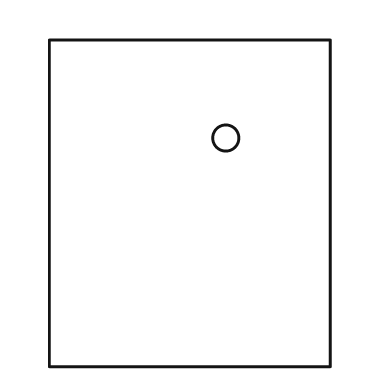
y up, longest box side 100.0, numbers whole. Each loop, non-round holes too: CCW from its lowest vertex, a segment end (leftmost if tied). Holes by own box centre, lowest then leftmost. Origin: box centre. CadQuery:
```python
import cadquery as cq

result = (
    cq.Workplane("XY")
    .moveTo(-43.0, -50.0)
    .lineTo(43.0, -50.0)
    .lineTo(43.0, 50.0)
    .lineTo(-43.0, 50.0)
    .close()
    .moveTo(11.0, 20.0)
    .circle(4.0)
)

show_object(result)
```